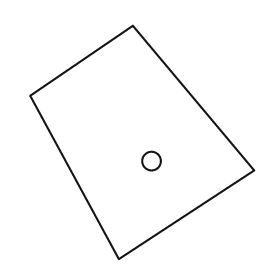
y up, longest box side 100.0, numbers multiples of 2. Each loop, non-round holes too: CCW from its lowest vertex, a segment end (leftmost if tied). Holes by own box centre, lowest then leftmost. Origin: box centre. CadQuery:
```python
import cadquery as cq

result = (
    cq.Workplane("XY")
    .moveTo(-10.0, -50.0)
    .lineTo(48.0, -12.0)
    .lineTo(-4.0, 50.0)
    .lineTo(-48.0, 20.0)
    .close()
    .moveTo(4.0, -8.0)
    .circle(4.0)
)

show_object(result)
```